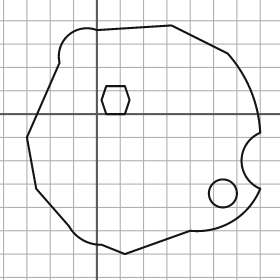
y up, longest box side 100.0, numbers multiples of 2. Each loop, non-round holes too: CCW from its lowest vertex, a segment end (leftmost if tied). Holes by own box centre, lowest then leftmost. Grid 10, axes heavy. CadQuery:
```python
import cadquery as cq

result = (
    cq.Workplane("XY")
    .moveTo(12.0, -60.0)
    .lineTo(40.0, -50.0)
    .threePointArc((58.0, -46.0), (70.0, -32.0))
    .threePointArc((62.0, -20.0), (70.0, -8.0))
    .threePointArc((66.0, 10.0), (56.0, 26.0))
    .lineTo(32.0, 38.0)
    .lineTo(0.0, 36.0)
    .threePointArc((-12.0, 34.0), (-16.0, 22.0))
    .lineTo(-30.0, -10.0)
    .lineTo(-26.0, -32.0)
    .lineTo(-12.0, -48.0)
    .threePointArc((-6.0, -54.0), (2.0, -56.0))
    .close()
    .moveTo(54.0, -34.0)
    .circle(6.0)
    .moveTo(4.0, 0.0)
    .lineTo(12.0, 0.0)
    .lineTo(14.0, 6.0)
    .lineTo(12.0, 12.0)
    .lineTo(4.0, 12.0)
    .lineTo(2.0, 6.0)
    .close()
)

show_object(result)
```